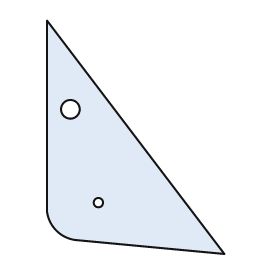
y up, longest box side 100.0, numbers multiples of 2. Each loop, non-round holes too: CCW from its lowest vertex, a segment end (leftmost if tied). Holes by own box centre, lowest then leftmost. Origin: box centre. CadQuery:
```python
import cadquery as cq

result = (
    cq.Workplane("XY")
    .moveTo(38.0, -50.0)
    .lineTo(-38.0, 50.0)
    .lineTo(-38.0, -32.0)
    .threePointArc((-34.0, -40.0), (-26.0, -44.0))
    .close()
    .moveTo(-16.0, -28.0)
    .circle(2.0)
    .moveTo(-28.0, 12.0)
    .circle(4.0)
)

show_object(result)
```